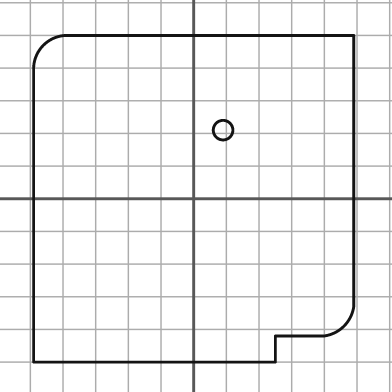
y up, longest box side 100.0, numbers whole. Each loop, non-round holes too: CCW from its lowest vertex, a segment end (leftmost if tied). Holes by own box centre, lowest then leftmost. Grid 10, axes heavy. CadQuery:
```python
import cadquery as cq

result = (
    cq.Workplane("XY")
    .moveTo(-49.0, -50.0)
    .lineTo(25.0, -50.0)
    .lineTo(25.0, -42.0)
    .lineTo(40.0, -42.0)
    .threePointArc((46.0, -39.0), (49.0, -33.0))
    .lineTo(49.0, 50.0)
    .lineTo(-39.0, 50.0)
    .threePointArc((-46.0, 47.0), (-49.0, 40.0))
    .close()
    .moveTo(9.0, 21.0)
    .circle(3.0)
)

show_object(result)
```